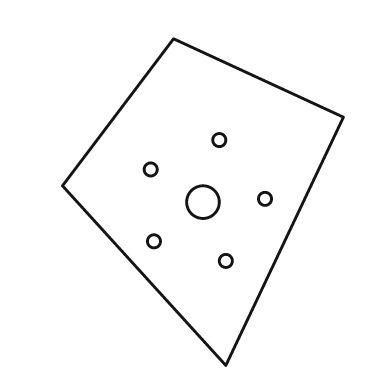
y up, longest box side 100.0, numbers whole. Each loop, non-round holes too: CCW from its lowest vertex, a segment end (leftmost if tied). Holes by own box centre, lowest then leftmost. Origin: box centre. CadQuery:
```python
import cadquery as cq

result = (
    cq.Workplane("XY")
    .moveTo(7.0, -50.0)
    .lineTo(43.0, 26.0)
    .lineTo(-9.0, 50.0)
    .lineTo(-43.0, 5.0)
    .close()
    .moveTo(7.0, -18.0)
    .circle(2.0)
    .moveTo(-15.0, -12.0)
    .circle(2.0)
    .moveTo(0.0, 0.0)
    .circle(5.0)
    .moveTo(19.0, 1.0)
    .circle(2.0)
    .moveTo(-16.0, 10.0)
    .circle(2.0)
    .moveTo(5.0, 19.0)
    .circle(2.0)
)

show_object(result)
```